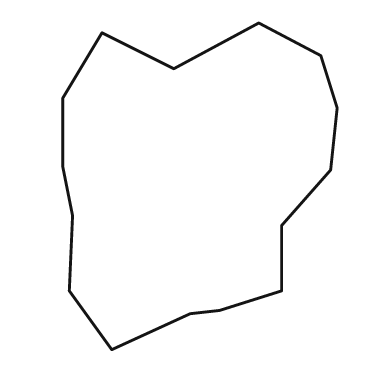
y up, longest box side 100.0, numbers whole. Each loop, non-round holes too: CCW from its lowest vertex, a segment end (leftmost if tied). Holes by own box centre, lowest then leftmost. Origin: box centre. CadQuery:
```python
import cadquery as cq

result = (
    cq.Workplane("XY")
    .moveTo(-27.0, -50.0)
    .lineTo(-3.0, -39.0)
    .lineTo(6.0, -38.0)
    .lineTo(25.0, -32.0)
    .lineTo(25.0, -12.0)
    .lineTo(40.0, 5.0)
    .lineTo(42.0, 24.0)
    .lineTo(37.0, 40.0)
    .lineTo(18.0, 50.0)
    .lineTo(-8.0, 36.0)
    .lineTo(-30.0, 47.0)
    .lineTo(-42.0, 27.0)
    .lineTo(-42.0, 6.0)
    .lineTo(-39.0, -9.0)
    .lineTo(-40.0, -32.0)
    .close()
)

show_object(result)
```